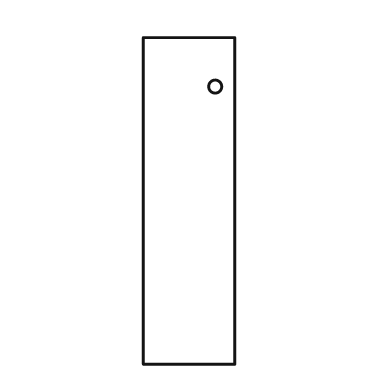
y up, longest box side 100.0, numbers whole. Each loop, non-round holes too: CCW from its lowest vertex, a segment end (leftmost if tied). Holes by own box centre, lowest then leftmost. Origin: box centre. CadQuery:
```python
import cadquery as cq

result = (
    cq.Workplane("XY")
    .moveTo(-14.0, -50.0)
    .lineTo(14.0, -50.0)
    .lineTo(14.0, 50.0)
    .lineTo(-14.0, 50.0)
    .close()
    .moveTo(8.0, 35.0)
    .circle(2.0)
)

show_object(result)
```